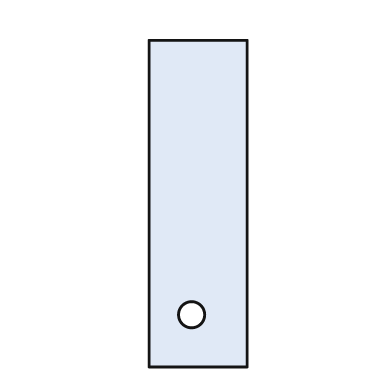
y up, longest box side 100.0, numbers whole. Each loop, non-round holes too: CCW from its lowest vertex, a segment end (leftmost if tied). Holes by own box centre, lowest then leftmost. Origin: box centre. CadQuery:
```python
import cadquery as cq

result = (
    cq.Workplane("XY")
    .moveTo(-15.0, -50.0)
    .lineTo(15.0, -50.0)
    .lineTo(15.0, 50.0)
    .lineTo(-15.0, 50.0)
    .close()
    .moveTo(-2.0, -34.0)
    .circle(4.0)
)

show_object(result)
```